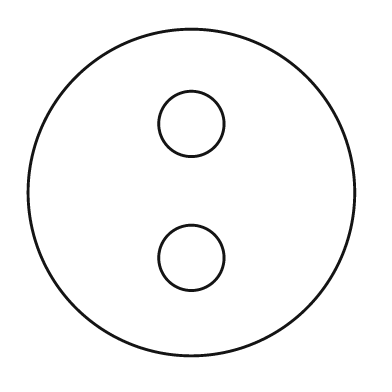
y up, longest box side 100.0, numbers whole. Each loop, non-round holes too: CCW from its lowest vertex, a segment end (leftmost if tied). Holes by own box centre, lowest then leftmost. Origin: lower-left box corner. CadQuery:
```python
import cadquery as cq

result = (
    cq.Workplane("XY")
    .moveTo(50.0, 50.0)
    .circle(50.0)
    .moveTo(50.0, 30.0)
    .circle(10.0)
    .moveTo(50.0, 71.0)
    .circle(10.0)
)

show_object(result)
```